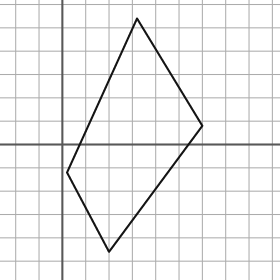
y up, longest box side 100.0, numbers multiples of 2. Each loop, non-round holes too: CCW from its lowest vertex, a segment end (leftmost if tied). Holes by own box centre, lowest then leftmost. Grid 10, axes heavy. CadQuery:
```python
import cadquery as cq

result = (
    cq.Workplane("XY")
    .moveTo(20.0, -46.0)
    .lineTo(60.0, 8.0)
    .lineTo(32.0, 54.0)
    .lineTo(2.0, -12.0)
    .close()
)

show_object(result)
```